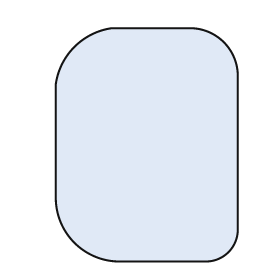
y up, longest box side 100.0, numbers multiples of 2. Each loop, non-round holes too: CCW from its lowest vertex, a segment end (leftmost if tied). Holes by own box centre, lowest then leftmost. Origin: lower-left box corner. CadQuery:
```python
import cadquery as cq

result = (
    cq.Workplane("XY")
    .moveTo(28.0, 0.0)
    .lineTo(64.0, 0.0)
    .threePointArc((74.0, 4.0), (78.0, 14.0))
    .lineTo(78.0, 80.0)
    .threePointArc((72.0, 94.0), (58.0, 100.0))
    .lineTo(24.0, 100.0)
    .threePointArc((8.0, 92.0), (0.0, 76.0))
    .lineTo(0.0, 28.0)
    .threePointArc((8.0, 8.0), (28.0, 0.0))
    .close()
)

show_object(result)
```